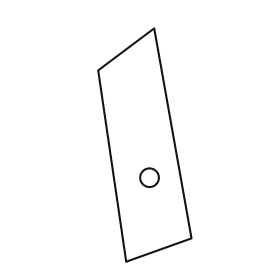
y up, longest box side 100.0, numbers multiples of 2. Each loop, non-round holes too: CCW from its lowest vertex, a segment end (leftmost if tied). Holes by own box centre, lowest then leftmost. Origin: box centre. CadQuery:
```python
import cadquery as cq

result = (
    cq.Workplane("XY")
    .moveTo(-8.0, -50.0)
    .lineTo(20.0, -40.0)
    .lineTo(4.0, 50.0)
    .lineTo(-20.0, 32.0)
    .close()
    .moveTo(2.0, -14.0)
    .circle(4.0)
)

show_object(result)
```